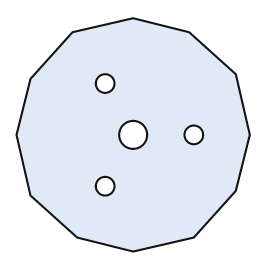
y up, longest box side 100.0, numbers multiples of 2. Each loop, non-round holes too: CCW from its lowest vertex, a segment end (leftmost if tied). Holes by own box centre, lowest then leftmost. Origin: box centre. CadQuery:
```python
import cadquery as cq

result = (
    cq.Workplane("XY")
    .moveTo(0.0, -50.0)
    .lineTo(26.0, -44.0)
    .lineTo(44.0, -24.0)
    .lineTo(50.0, 0.0)
    .lineTo(44.0, 26.0)
    .lineTo(24.0, 44.0)
    .lineTo(0.0, 50.0)
    .lineTo(-26.0, 44.0)
    .lineTo(-44.0, 24.0)
    .lineTo(-50.0, 0.0)
    .lineTo(-44.0, -26.0)
    .lineTo(-24.0, -44.0)
    .close()
    .moveTo(-12.0, -22.0)
    .circle(4.0)
    .moveTo(0.0, 0.0)
    .circle(6.0)
    .moveTo(26.0, 0.0)
    .circle(4.0)
    .moveTo(-12.0, 22.0)
    .circle(4.0)
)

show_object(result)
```